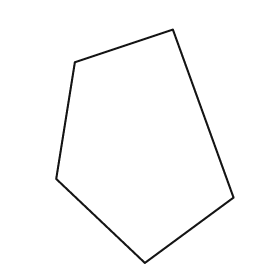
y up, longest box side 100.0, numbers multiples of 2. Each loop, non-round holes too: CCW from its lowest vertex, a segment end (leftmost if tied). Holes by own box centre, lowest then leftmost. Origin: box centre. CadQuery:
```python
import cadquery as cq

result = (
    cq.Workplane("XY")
    .moveTo(0.0, -50.0)
    .lineTo(38.0, -22.0)
    .lineTo(12.0, 50.0)
    .lineTo(-30.0, 36.0)
    .lineTo(-38.0, -14.0)
    .close()
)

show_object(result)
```